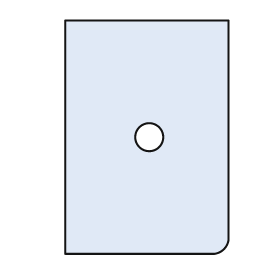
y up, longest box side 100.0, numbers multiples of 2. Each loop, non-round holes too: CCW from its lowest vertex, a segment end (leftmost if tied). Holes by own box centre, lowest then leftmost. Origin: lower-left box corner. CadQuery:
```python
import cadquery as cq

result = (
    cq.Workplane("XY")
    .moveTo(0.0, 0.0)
    .lineTo(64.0, 0.0)
    .threePointArc((68.0, 2.0), (70.0, 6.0))
    .lineTo(70.0, 100.0)
    .lineTo(0.0, 100.0)
    .close()
    .moveTo(36.0, 50.0)
    .circle(6.0)
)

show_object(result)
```